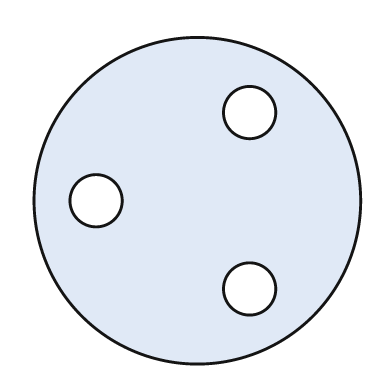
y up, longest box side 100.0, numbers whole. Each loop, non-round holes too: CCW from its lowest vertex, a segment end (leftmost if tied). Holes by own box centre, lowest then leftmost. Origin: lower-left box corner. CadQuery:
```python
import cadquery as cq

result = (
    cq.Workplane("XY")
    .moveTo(50.0, 50.0)
    .circle(50.0)
    .moveTo(66.0, 23.0)
    .circle(8.0)
    .moveTo(19.0, 50.0)
    .circle(8.0)
    .moveTo(66.0, 77.0)
    .circle(8.0)
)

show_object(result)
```